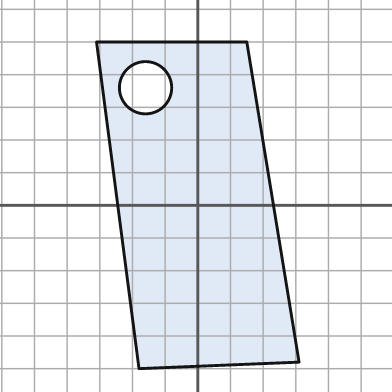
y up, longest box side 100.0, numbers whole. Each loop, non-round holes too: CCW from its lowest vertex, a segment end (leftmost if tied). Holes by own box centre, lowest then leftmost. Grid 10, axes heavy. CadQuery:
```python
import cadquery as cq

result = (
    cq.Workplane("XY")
    .moveTo(-18.0, -50.0)
    .lineTo(31.0, -48.0)
    .lineTo(15.0, 50.0)
    .lineTo(-31.0, 50.0)
    .close()
    .moveTo(-16.0, 36.0)
    .circle(8.0)
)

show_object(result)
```